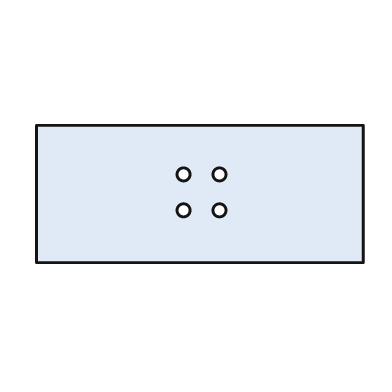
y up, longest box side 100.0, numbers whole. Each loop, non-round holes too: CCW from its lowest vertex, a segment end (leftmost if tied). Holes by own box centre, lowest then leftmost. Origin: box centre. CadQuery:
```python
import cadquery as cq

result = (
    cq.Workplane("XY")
    .moveTo(-50.0, -21.0)
    .lineTo(50.0, -21.0)
    .lineTo(50.0, 21.0)
    .lineTo(-50.0, 21.0)
    .close()
    .moveTo(-5.0, -5.0)
    .circle(2.0)
    .moveTo(6.0, -5.0)
    .circle(2.0)
    .moveTo(-5.0, 6.0)
    .circle(2.0)
    .moveTo(6.0, 6.0)
    .circle(2.0)
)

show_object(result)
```